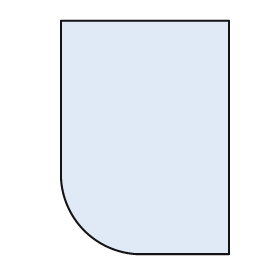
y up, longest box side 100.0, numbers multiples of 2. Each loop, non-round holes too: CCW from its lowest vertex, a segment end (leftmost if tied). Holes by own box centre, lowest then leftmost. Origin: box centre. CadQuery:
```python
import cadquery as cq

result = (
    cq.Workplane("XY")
    .moveTo(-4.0, -50.0)
    .lineTo(36.0, -50.0)
    .lineTo(36.0, 50.0)
    .lineTo(-36.0, 50.0)
    .lineTo(-36.0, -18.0)
    .threePointArc((-26.0, -40.0), (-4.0, -50.0))
    .close()
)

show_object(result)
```